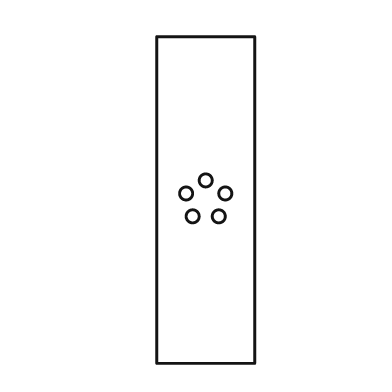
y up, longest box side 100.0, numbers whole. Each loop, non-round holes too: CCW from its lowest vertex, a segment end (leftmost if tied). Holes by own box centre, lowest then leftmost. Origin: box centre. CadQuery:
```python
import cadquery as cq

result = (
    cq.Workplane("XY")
    .moveTo(-15.0, -50.0)
    .lineTo(15.0, -50.0)
    .lineTo(15.0, 50.0)
    .lineTo(-15.0, 50.0)
    .close()
    .moveTo(-4.0, -5.0)
    .circle(2.0)
    .moveTo(4.0, -5.0)
    .circle(2.0)
    .moveTo(-6.0, 2.0)
    .circle(2.0)
    .moveTo(6.0, 2.0)
    .circle(2.0)
    .moveTo(0.0, 6.0)
    .circle(2.0)
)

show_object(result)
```